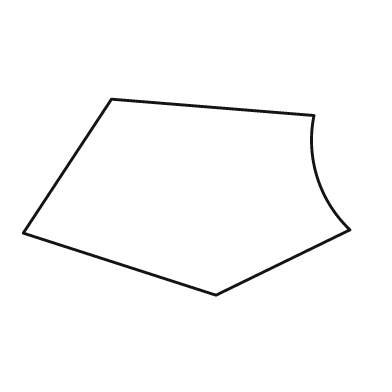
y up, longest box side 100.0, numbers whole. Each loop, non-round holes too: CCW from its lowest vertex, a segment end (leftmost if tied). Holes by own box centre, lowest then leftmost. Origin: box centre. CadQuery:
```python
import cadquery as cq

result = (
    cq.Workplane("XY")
    .moveTo(9.0, -30.0)
    .lineTo(50.0, -10.0)
    .threePointArc((40.0, 6.0), (39.0, 25.0))
    .lineTo(-23.0, 30.0)
    .lineTo(-50.0, -11.0)
    .close()
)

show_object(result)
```